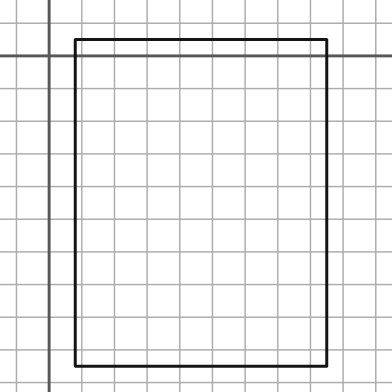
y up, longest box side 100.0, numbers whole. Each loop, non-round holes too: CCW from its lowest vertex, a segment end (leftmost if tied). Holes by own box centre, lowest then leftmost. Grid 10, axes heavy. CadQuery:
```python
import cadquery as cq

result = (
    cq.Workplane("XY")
    .moveTo(8.0, -95.0)
    .lineTo(85.0, -95.0)
    .lineTo(85.0, 5.0)
    .lineTo(8.0, 5.0)
    .close()
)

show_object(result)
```